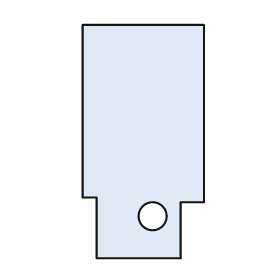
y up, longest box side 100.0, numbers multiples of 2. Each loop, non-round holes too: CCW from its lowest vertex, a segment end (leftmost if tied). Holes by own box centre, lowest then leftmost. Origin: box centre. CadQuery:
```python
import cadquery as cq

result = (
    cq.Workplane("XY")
    .moveTo(-20.0, -50.0)
    .lineTo(16.0, -50.0)
    .lineTo(16.0, -26.0)
    .lineTo(26.0, -26.0)
    .lineTo(26.0, 50.0)
    .lineTo(-26.0, 50.0)
    .lineTo(-26.0, -24.0)
    .lineTo(-20.0, -24.0)
    .close()
    .moveTo(4.0, -32.0)
    .circle(6.0)
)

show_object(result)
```